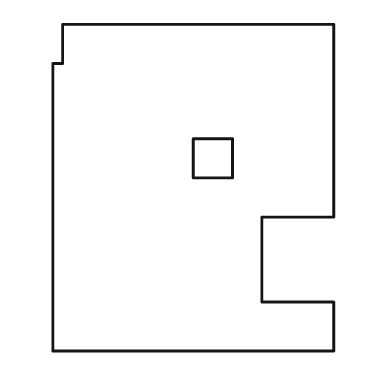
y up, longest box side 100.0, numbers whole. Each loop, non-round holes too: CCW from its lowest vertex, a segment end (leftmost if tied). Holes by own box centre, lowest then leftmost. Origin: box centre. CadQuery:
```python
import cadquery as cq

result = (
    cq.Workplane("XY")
    .moveTo(-43.0, -50.0)
    .lineTo(43.0, -50.0)
    .lineTo(43.0, -35.0)
    .lineTo(21.0, -35.0)
    .lineTo(21.0, -9.0)
    .lineTo(43.0, -9.0)
    .lineTo(43.0, 50.0)
    .lineTo(-40.0, 50.0)
    .lineTo(-40.0, 38.0)
    .lineTo(-43.0, 38.0)
    .close()
    .moveTo(0.0, 3.0)
    .lineTo(12.0, 3.0)
    .lineTo(12.0, 15.0)
    .lineTo(0.0, 15.0)
    .close()
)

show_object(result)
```